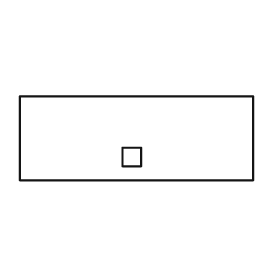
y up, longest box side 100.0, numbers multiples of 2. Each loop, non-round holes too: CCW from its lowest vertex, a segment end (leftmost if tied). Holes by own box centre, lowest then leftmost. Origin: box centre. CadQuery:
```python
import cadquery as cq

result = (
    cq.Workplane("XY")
    .moveTo(-50.0, -18.0)
    .lineTo(50.0, -18.0)
    .lineTo(50.0, 18.0)
    .lineTo(-50.0, 18.0)
    .close()
    .moveTo(-6.0, -12.0)
    .lineTo(2.0, -12.0)
    .lineTo(2.0, -4.0)
    .lineTo(-6.0, -4.0)
    .close()
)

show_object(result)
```